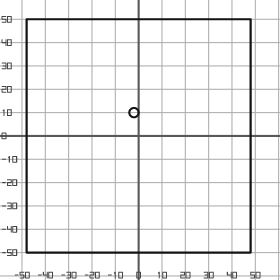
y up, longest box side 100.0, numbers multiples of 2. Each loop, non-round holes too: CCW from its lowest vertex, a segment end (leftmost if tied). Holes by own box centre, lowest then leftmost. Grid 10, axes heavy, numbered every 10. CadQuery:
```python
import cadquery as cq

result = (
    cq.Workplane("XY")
    .moveTo(-48.0, -50.0)
    .lineTo(48.0, -50.0)
    .lineTo(48.0, 50.0)
    .lineTo(-48.0, 50.0)
    .close()
    .moveTo(-2.0, 10.0)
    .circle(2.0)
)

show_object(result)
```